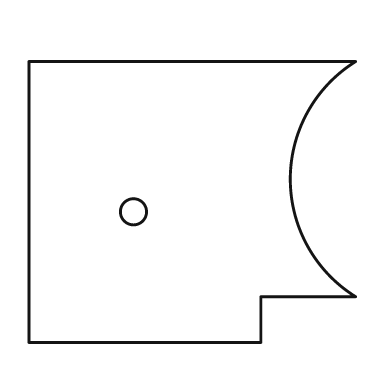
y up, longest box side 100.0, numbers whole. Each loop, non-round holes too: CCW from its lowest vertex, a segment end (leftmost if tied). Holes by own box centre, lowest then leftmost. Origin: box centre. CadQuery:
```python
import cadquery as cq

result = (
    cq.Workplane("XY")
    .moveTo(-50.0, -43.0)
    .lineTo(21.0, -43.0)
    .lineTo(21.0, -29.0)
    .lineTo(50.0, -29.0)
    .threePointArc((30.0, 7.0), (50.0, 43.0))
    .lineTo(-50.0, 43.0)
    .close()
    .moveTo(-18.0, -3.0)
    .circle(4.0)
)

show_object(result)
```